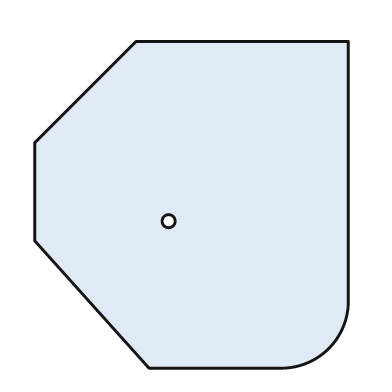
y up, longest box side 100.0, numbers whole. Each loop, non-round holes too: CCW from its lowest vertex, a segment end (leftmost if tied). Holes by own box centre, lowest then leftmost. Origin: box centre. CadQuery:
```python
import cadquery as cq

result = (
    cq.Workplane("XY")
    .moveTo(-13.0, -50.0)
    .lineTo(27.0, -50.0)
    .threePointArc((42.0, -44.0), (48.0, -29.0))
    .lineTo(48.0, 50.0)
    .lineTo(-17.0, 50.0)
    .lineTo(-48.0, 19.0)
    .lineTo(-48.0, -11.0)
    .close()
    .moveTo(-7.0, -5.0)
    .circle(2.0)
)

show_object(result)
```